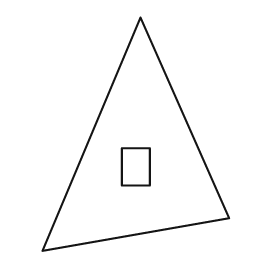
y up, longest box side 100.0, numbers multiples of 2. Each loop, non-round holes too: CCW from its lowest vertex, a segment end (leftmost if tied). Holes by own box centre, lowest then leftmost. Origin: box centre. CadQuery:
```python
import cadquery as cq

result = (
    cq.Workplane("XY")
    .moveTo(-40.0, -50.0)
    .lineTo(40.0, -36.0)
    .lineTo(2.0, 50.0)
    .close()
    .moveTo(-6.0, -22.0)
    .lineTo(6.0, -22.0)
    .lineTo(6.0, -6.0)
    .lineTo(-6.0, -6.0)
    .close()
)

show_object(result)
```